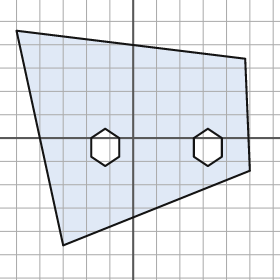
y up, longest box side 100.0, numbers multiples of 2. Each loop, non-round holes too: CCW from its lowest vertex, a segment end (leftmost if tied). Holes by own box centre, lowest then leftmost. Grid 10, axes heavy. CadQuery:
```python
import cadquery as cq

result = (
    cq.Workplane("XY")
    .moveTo(-30.0, -46.0)
    .lineTo(50.0, -14.0)
    .lineTo(48.0, 34.0)
    .lineTo(-50.0, 46.0)
    .close()
    .moveTo(-12.0, -12.0)
    .lineTo(-6.0, -8.0)
    .lineTo(-6.0, 0.0)
    .lineTo(-12.0, 4.0)
    .lineTo(-18.0, 0.0)
    .lineTo(-18.0, -8.0)
    .close()
    .moveTo(32.0, -12.0)
    .lineTo(38.0, -8.0)
    .lineTo(38.0, 0.0)
    .lineTo(32.0, 4.0)
    .lineTo(26.0, 0.0)
    .lineTo(26.0, -8.0)
    .close()
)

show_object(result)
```